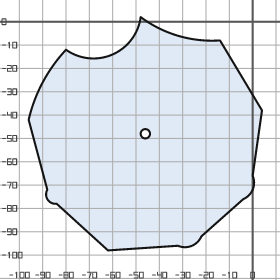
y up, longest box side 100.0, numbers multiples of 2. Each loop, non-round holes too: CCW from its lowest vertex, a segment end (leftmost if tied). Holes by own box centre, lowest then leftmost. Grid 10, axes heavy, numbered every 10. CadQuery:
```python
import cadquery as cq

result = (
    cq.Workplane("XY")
    .moveTo(-62.0, -98.0)
    .lineTo(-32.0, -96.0)
    .threePointArc((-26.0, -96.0), (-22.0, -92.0))
    .lineTo(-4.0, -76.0)
    .threePointArc((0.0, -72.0), (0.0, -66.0))
    .lineTo(4.0, -38.0)
    .lineTo(-14.0, -8.0)
    .threePointArc((-32.0, -6.0), (-48.0, 2.0))
    .threePointArc((-60.0, -14.0), (-80.0, -12.0))
    .threePointArc((-90.0, -26.0), (-96.0, -42.0))
    .lineTo(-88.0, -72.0)
    .threePointArc((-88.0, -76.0), (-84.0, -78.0))
    .close()
    .moveTo(-46.0, -48.0)
    .circle(2.0)
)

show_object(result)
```